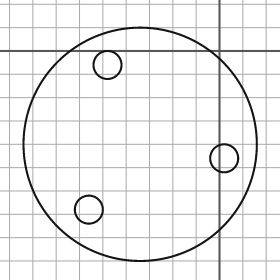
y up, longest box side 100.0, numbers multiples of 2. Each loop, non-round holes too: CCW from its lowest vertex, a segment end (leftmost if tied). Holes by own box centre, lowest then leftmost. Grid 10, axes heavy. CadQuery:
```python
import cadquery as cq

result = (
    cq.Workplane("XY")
    .moveTo(-34.0, -40.0)
    .circle(50.0)
    .moveTo(-56.0, -68.0)
    .circle(6.0)
    .moveTo(2.0, -46.0)
    .circle(6.0)
    .moveTo(-48.0, -6.0)
    .circle(6.0)
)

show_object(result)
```